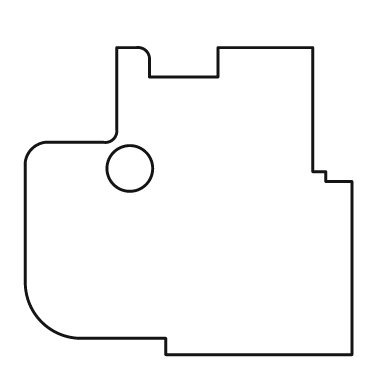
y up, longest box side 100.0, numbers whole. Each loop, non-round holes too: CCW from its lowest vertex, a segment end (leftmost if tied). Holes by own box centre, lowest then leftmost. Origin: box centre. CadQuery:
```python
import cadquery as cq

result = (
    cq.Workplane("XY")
    .moveTo(-7.0, -47.0)
    .lineTo(50.0, -47.0)
    .lineTo(50.0, 6.0)
    .lineTo(42.0, 6.0)
    .lineTo(42.0, 9.0)
    .lineTo(38.0, 9.0)
    .lineTo(38.0, 47.0)
    .lineTo(9.0, 47.0)
    .lineTo(9.0, 38.0)
    .lineTo(-12.0, 38.0)
    .lineTo(-12.0, 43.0)
    .threePointArc((-13.0, 46.0), (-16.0, 47.0))
    .lineTo(-22.0, 47.0)
    .lineTo(-22.0, 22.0)
    .threePointArc((-23.0, 19.0), (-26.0, 18.0))
    .lineTo(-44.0, 18.0)
    .threePointArc((-48.0, 16.0), (-50.0, 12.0))
    .lineTo(-50.0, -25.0)
    .threePointArc((-45.0, -37.0), (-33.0, -42.0))
    .lineTo(-7.0, -42.0)
    .close()
    .moveTo(-18.0, 10.0)
    .circle(7.0)
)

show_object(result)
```